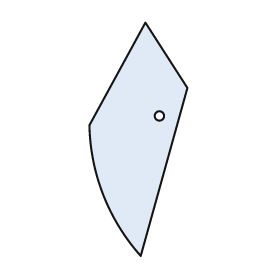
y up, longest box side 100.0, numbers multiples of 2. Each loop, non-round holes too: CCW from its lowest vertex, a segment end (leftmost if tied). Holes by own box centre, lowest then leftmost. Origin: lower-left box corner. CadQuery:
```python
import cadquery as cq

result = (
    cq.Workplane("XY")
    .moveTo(22.0, 0.0)
    .lineTo(42.0, 72.0)
    .lineTo(24.0, 100.0)
    .lineTo(0.0, 56.0)
    .threePointArc((6.0, 26.0), (22.0, 0.0))
    .close()
    .moveTo(30.0, 60.0)
    .circle(2.0)
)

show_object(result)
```